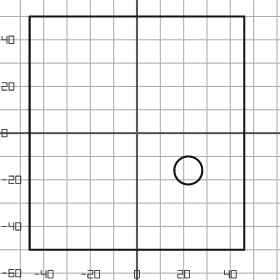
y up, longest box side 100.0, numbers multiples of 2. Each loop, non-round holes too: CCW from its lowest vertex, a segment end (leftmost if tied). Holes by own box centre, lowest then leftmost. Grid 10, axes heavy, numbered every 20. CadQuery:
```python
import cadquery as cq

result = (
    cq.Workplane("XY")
    .moveTo(-46.0, -50.0)
    .lineTo(46.0, -50.0)
    .lineTo(46.0, 50.0)
    .lineTo(-46.0, 50.0)
    .close()
    .moveTo(22.0, -16.0)
    .circle(6.0)
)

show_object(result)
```